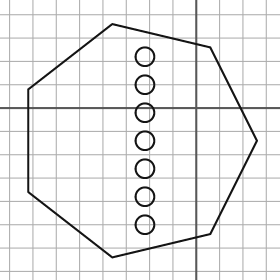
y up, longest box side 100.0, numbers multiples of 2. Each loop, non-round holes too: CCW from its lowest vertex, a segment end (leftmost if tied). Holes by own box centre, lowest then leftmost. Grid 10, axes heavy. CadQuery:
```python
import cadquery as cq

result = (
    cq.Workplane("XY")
    .moveTo(-36.0, -64.0)
    .lineTo(6.0, -54.0)
    .lineTo(26.0, -14.0)
    .lineTo(6.0, 26.0)
    .lineTo(-36.0, 36.0)
    .lineTo(-72.0, 8.0)
    .lineTo(-72.0, -36.0)
    .close()
    .moveTo(-22.0, -50.0)
    .circle(4.0)
    .moveTo(-22.0, -38.0)
    .circle(4.0)
    .moveTo(-22.0, -26.0)
    .circle(4.0)
    .moveTo(-22.0, -14.0)
    .circle(4.0)
    .moveTo(-22.0, -2.0)
    .circle(4.0)
    .moveTo(-22.0, 10.0)
    .circle(4.0)
    .moveTo(-22.0, 22.0)
    .circle(4.0)
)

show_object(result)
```